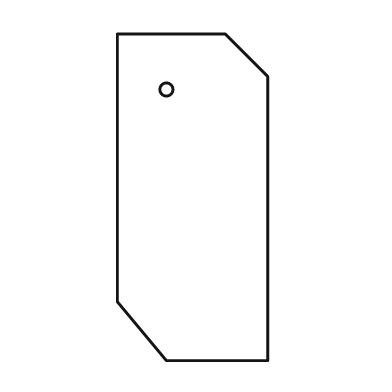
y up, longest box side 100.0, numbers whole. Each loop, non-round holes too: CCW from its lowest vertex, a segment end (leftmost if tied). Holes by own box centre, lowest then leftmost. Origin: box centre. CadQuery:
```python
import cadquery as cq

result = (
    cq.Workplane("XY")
    .moveTo(-8.0, -50.0)
    .lineTo(23.0, -50.0)
    .lineTo(23.0, 37.0)
    .lineTo(10.0, 50.0)
    .lineTo(-23.0, 50.0)
    .lineTo(-23.0, -32.0)
    .close()
    .moveTo(-8.0, 33.0)
    .circle(2.0)
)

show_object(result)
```